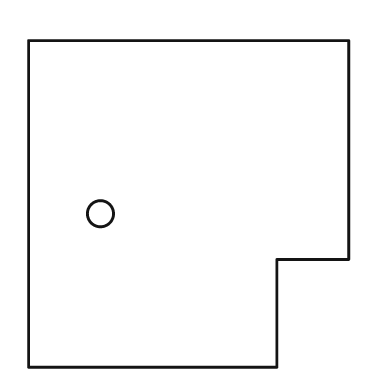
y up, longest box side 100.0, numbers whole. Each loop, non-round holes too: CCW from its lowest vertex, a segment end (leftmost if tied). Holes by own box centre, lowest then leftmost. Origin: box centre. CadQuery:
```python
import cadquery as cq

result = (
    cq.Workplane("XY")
    .moveTo(-49.0, -50.0)
    .lineTo(27.0, -50.0)
    .lineTo(27.0, -17.0)
    .lineTo(49.0, -17.0)
    .lineTo(49.0, 50.0)
    .lineTo(-49.0, 50.0)
    .close()
    .moveTo(-27.0, -3.0)
    .circle(4.0)
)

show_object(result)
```